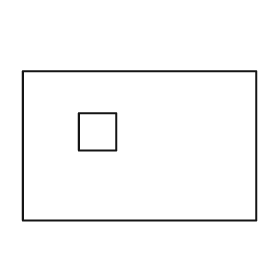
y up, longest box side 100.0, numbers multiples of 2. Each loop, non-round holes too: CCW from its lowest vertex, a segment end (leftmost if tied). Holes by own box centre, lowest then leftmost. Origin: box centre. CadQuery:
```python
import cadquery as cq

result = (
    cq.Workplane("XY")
    .moveTo(-50.0, -32.0)
    .lineTo(50.0, -32.0)
    .lineTo(50.0, 32.0)
    .lineTo(-50.0, 32.0)
    .close()
    .moveTo(-26.0, -2.0)
    .lineTo(-10.0, -2.0)
    .lineTo(-10.0, 14.0)
    .lineTo(-26.0, 14.0)
    .close()
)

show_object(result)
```